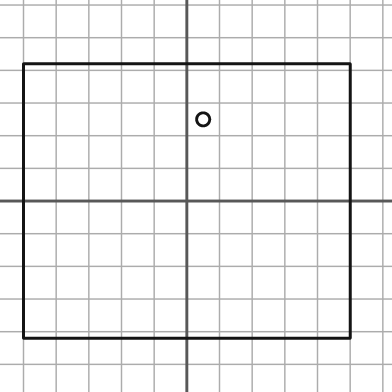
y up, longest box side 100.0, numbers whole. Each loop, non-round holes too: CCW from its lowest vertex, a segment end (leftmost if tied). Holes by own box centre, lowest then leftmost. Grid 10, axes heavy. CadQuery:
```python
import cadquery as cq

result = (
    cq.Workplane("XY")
    .moveTo(-50.0, -42.0)
    .lineTo(50.0, -42.0)
    .lineTo(50.0, 42.0)
    .lineTo(-50.0, 42.0)
    .close()
    .moveTo(5.0, 25.0)
    .circle(2.0)
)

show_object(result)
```